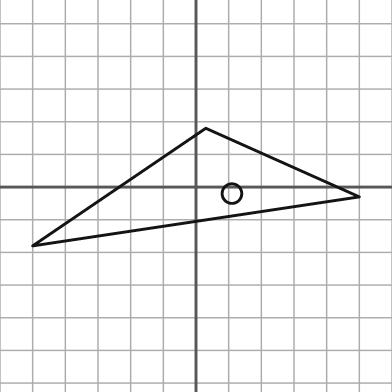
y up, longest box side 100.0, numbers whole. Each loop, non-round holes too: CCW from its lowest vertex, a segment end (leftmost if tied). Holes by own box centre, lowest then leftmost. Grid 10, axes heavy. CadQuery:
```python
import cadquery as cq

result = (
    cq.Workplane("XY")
    .moveTo(-50.0, -18.0)
    .lineTo(50.0, -3.0)
    .lineTo(3.0, 18.0)
    .close()
    .moveTo(11.0, -2.0)
    .circle(3.0)
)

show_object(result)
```